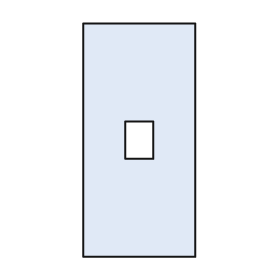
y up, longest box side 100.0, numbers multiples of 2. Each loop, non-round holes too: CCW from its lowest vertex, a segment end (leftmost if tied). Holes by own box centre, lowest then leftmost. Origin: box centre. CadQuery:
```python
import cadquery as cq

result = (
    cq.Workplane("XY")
    .moveTo(-24.0, -50.0)
    .lineTo(24.0, -50.0)
    .lineTo(24.0, 50.0)
    .lineTo(-24.0, 50.0)
    .close()
    .moveTo(-6.0, -8.0)
    .lineTo(6.0, -8.0)
    .lineTo(6.0, 8.0)
    .lineTo(-6.0, 8.0)
    .close()
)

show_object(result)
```